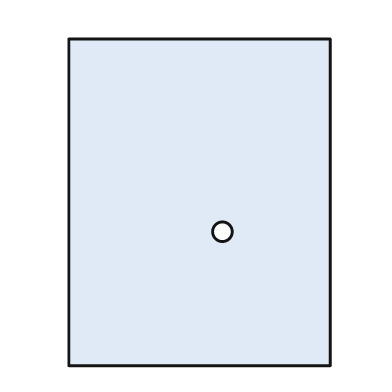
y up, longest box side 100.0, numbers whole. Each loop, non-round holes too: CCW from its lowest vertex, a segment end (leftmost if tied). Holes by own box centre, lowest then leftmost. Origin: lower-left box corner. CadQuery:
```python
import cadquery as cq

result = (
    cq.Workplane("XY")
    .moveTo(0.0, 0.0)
    .lineTo(80.0, 0.0)
    .lineTo(80.0, 100.0)
    .lineTo(0.0, 100.0)
    .close()
    .moveTo(47.0, 41.0)
    .circle(3.0)
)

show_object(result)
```